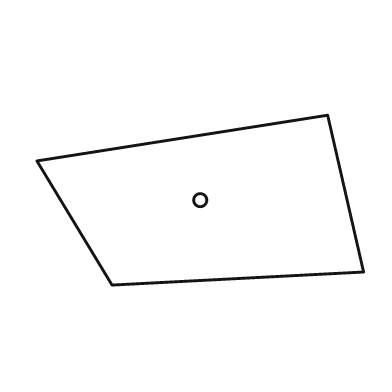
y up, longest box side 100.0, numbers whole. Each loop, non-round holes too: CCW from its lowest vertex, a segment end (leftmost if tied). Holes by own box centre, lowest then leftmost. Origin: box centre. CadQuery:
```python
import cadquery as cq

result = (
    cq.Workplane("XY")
    .moveTo(-27.0, -26.0)
    .lineTo(50.0, -22.0)
    .lineTo(39.0, 26.0)
    .lineTo(-50.0, 12.0)
    .close()
    .moveTo(0.0, 0.0)
    .circle(2.0)
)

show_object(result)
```